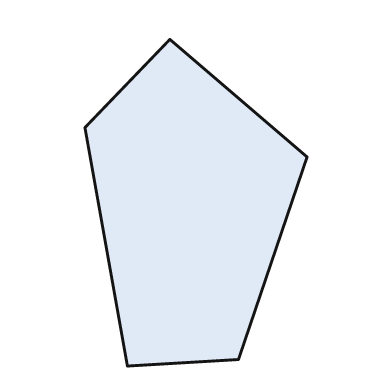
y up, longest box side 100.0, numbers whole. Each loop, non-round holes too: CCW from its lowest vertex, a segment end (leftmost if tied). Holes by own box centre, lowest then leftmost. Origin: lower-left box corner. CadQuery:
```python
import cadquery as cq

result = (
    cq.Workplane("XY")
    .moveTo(13.0, 0.0)
    .lineTo(47.0, 2.0)
    .lineTo(68.0, 64.0)
    .lineTo(26.0, 100.0)
    .lineTo(0.0, 73.0)
    .close()
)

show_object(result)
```